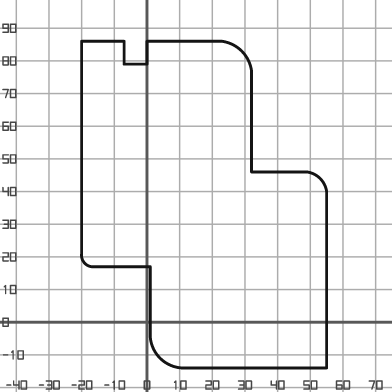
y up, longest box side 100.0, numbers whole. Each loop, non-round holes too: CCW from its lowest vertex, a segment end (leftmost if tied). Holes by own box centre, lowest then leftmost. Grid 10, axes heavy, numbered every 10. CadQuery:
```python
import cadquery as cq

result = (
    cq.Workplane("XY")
    .moveTo(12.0, -14.0)
    .lineTo(55.0, -14.0)
    .lineTo(55.0, 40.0)
    .threePointArc((53.0, 44.0), (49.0, 46.0))
    .lineTo(32.0, 46.0)
    .lineTo(32.0, 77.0)
    .threePointArc((29.0, 83.0), (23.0, 86.0))
    .lineTo(0.0, 86.0)
    .lineTo(0.0, 79.0)
    .lineTo(-7.0, 79.0)
    .lineTo(-7.0, 86.0)
    .lineTo(-20.0, 86.0)
    .lineTo(-20.0, 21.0)
    .threePointArc((-19.0, 18.0), (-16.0, 17.0))
    .lineTo(1.0, 17.0)
    .lineTo(1.0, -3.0)
    .threePointArc((4.0, -11.0), (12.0, -14.0))
    .close()
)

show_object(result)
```